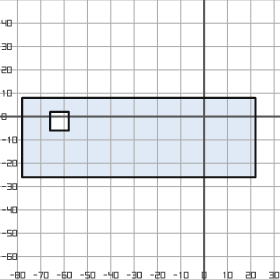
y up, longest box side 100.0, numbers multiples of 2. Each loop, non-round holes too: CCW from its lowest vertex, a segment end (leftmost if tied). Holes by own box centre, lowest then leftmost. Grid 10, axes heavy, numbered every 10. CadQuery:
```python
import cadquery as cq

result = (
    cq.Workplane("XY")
    .moveTo(-78.0, -26.0)
    .lineTo(22.0, -26.0)
    .lineTo(22.0, 8.0)
    .lineTo(-78.0, 8.0)
    .close()
    .moveTo(-66.0, -6.0)
    .lineTo(-58.0, -6.0)
    .lineTo(-58.0, 2.0)
    .lineTo(-66.0, 2.0)
    .close()
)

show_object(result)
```